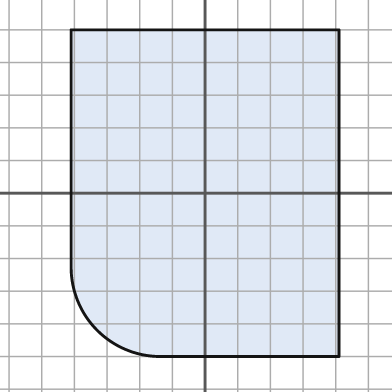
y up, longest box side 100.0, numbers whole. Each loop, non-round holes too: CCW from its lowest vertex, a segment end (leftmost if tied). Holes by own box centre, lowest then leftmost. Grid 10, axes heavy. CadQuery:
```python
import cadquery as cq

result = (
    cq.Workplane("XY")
    .moveTo(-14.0, -50.0)
    .lineTo(41.0, -50.0)
    .lineTo(41.0, 50.0)
    .lineTo(-41.0, 50.0)
    .lineTo(-41.0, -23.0)
    .threePointArc((-33.0, -42.0), (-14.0, -50.0))
    .close()
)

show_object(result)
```